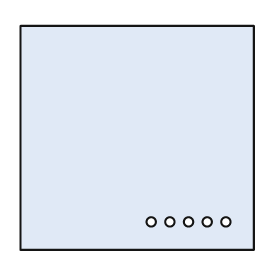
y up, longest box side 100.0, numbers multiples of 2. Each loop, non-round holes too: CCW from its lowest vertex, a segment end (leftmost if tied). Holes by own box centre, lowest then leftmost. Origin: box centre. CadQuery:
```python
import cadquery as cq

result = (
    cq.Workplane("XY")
    .moveTo(-50.0, -48.0)
    .lineTo(50.0, -48.0)
    .lineTo(50.0, 48.0)
    .lineTo(-50.0, 48.0)
    .close()
    .moveTo(6.0, -36.0)
    .circle(2.0)
    .moveTo(14.0, -36.0)
    .circle(2.0)
    .moveTo(22.0, -36.0)
    .circle(2.0)
    .moveTo(30.0, -36.0)
    .circle(2.0)
    .moveTo(38.0, -36.0)
    .circle(2.0)
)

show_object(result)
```